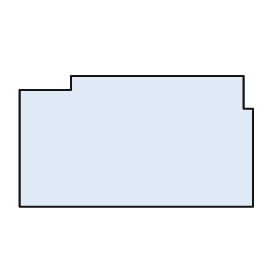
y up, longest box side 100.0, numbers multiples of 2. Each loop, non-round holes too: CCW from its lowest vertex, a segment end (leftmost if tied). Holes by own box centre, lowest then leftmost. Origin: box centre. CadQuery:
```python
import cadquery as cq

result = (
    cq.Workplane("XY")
    .moveTo(-50.0, -28.0)
    .lineTo(50.0, -28.0)
    .lineTo(50.0, 14.0)
    .lineTo(46.0, 14.0)
    .lineTo(46.0, 28.0)
    .lineTo(-28.0, 28.0)
    .lineTo(-28.0, 22.0)
    .lineTo(-50.0, 22.0)
    .close()
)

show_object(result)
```